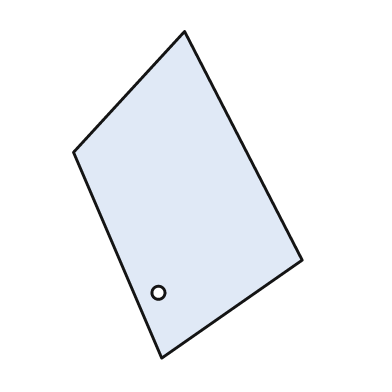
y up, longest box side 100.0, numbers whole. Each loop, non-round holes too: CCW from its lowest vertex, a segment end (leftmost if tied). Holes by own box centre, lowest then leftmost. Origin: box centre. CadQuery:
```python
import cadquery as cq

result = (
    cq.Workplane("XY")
    .moveTo(-8.0, -50.0)
    .lineTo(35.0, -20.0)
    .lineTo(-1.0, 50.0)
    .lineTo(-35.0, 13.0)
    .close()
    .moveTo(-9.0, -30.0)
    .circle(2.0)
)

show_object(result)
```